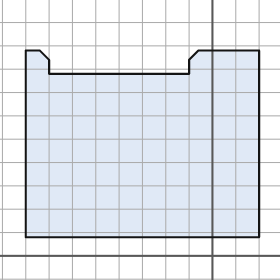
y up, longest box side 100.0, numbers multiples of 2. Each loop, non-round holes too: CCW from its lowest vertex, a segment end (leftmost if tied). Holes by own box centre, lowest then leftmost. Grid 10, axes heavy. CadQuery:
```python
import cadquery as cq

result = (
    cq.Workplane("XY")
    .moveTo(-80.0, 8.0)
    .lineTo(20.0, 8.0)
    .lineTo(20.0, 88.0)
    .lineTo(-6.0, 88.0)
    .lineTo(-10.0, 84.0)
    .lineTo(-10.0, 78.0)
    .lineTo(-70.0, 78.0)
    .lineTo(-70.0, 84.0)
    .lineTo(-74.0, 88.0)
    .lineTo(-80.0, 88.0)
    .close()
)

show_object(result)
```